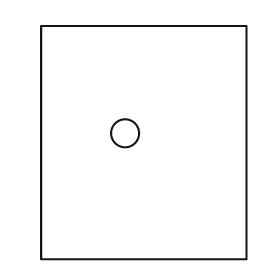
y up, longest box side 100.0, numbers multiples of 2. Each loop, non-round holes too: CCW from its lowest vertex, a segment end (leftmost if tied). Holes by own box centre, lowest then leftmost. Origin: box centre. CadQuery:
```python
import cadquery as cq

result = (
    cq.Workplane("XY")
    .moveTo(-44.0, -50.0)
    .lineTo(44.0, -50.0)
    .lineTo(44.0, 50.0)
    .lineTo(-44.0, 50.0)
    .close()
    .moveTo(-8.0, 4.0)
    .circle(6.0)
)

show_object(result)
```